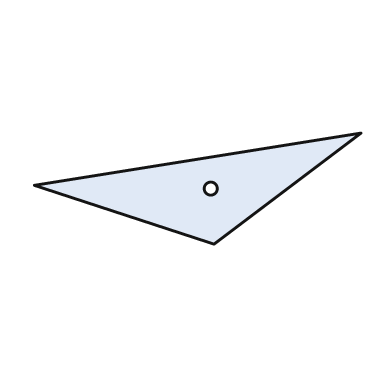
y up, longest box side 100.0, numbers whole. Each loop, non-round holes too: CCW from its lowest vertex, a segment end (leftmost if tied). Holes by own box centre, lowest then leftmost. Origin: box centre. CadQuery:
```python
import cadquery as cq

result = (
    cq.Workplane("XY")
    .moveTo(5.0, -17.0)
    .lineTo(50.0, 17.0)
    .lineTo(-50.0, 1.0)
    .close()
    .moveTo(4.0, 0.0)
    .circle(2.0)
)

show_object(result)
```